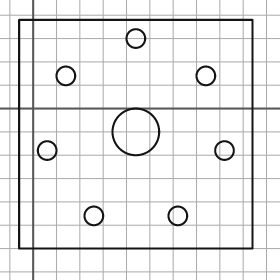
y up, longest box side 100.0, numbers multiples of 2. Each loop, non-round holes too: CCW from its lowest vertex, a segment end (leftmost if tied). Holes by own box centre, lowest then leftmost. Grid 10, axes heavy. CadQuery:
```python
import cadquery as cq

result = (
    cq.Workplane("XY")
    .moveTo(-6.0, -60.0)
    .lineTo(94.0, -60.0)
    .lineTo(94.0, 38.0)
    .lineTo(-6.0, 38.0)
    .close()
    .moveTo(26.0, -46.0)
    .circle(4.0)
    .moveTo(62.0, -46.0)
    .circle(4.0)
    .moveTo(6.0, -18.0)
    .circle(4.0)
    .moveTo(82.0, -18.0)
    .circle(4.0)
    .moveTo(44.0, -10.0)
    .circle(10.0)
    .moveTo(14.0, 14.0)
    .circle(4.0)
    .moveTo(74.0, 14.0)
    .circle(4.0)
    .moveTo(44.0, 30.0)
    .circle(4.0)
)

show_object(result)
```